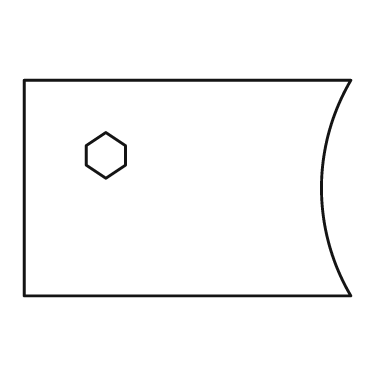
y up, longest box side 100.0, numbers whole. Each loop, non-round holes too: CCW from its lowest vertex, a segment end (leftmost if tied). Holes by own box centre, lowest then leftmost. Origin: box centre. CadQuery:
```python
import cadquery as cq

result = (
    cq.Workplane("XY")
    .moveTo(-50.0, -33.0)
    .lineTo(50.0, -33.0)
    .threePointArc((41.0, 0.0), (50.0, 33.0))
    .lineTo(-50.0, 33.0)
    .close()
    .moveTo(-25.0, 3.0)
    .lineTo(-19.0, 7.0)
    .lineTo(-19.0, 13.0)
    .lineTo(-25.0, 17.0)
    .lineTo(-31.0, 13.0)
    .lineTo(-31.0, 7.0)
    .close()
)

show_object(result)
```